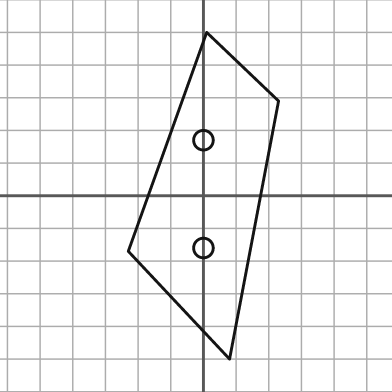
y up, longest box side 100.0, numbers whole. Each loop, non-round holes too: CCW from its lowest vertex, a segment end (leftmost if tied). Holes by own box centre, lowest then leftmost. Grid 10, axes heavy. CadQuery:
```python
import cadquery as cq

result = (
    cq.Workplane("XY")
    .moveTo(8.0, -50.0)
    .lineTo(23.0, 29.0)
    .lineTo(1.0, 50.0)
    .lineTo(-23.0, -17.0)
    .close()
    .moveTo(0.0, -16.0)
    .circle(3.0)
    .moveTo(0.0, 17.0)
    .circle(3.0)
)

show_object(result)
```